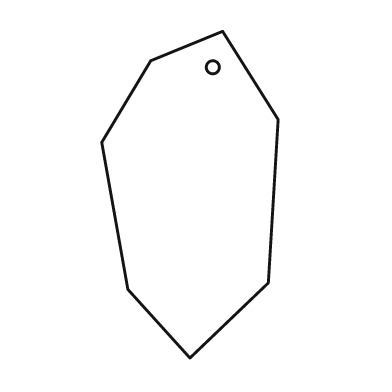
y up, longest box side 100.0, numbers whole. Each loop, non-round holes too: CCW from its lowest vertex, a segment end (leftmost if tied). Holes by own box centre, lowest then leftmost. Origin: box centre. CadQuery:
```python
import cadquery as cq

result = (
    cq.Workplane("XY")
    .moveTo(0.0, -50.0)
    .lineTo(24.0, -27.0)
    .lineTo(27.0, 23.0)
    .lineTo(10.0, 50.0)
    .lineTo(-12.0, 41.0)
    .lineTo(-27.0, 16.0)
    .lineTo(-19.0, -29.0)
    .close()
    .moveTo(7.0, 39.0)
    .circle(2.0)
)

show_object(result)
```